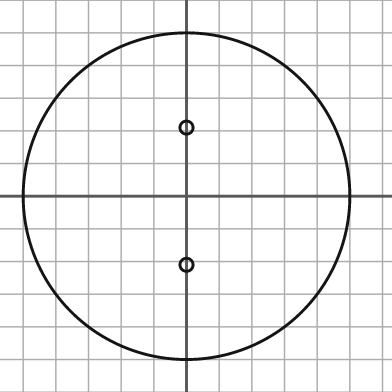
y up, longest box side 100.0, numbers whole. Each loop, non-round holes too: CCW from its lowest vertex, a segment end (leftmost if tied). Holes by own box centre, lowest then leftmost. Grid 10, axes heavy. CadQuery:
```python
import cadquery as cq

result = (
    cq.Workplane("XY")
    .moveTo(0.0, 0.0)
    .circle(50.0)
    .moveTo(0.0, -21.0)
    .circle(2.0)
    .moveTo(0.0, 21.0)
    .circle(2.0)
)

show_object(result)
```